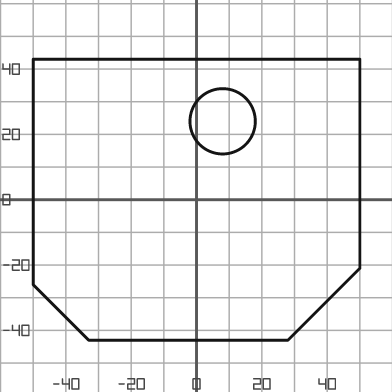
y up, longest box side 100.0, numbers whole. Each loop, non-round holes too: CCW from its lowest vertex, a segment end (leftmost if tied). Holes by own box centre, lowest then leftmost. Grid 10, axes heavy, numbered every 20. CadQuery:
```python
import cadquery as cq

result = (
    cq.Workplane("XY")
    .moveTo(-33.0, -43.0)
    .lineTo(28.0, -43.0)
    .lineTo(50.0, -21.0)
    .lineTo(50.0, 43.0)
    .lineTo(-50.0, 43.0)
    .lineTo(-50.0, -26.0)
    .close()
    .moveTo(8.0, 24.0)
    .circle(10.0)
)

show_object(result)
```